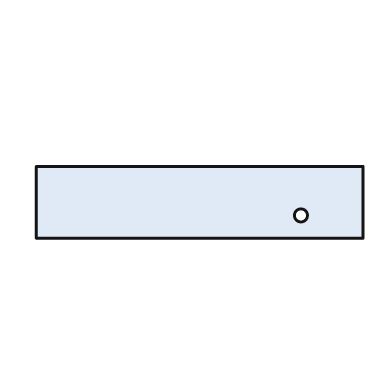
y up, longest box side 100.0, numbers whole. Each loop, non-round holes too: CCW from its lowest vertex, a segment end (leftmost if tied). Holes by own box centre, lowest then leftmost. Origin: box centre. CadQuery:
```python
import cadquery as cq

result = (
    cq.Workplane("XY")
    .moveTo(-50.0, -11.0)
    .lineTo(50.0, -11.0)
    .lineTo(50.0, 11.0)
    .lineTo(-50.0, 11.0)
    .close()
    .moveTo(31.0, -4.0)
    .circle(2.0)
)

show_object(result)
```